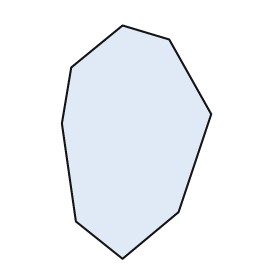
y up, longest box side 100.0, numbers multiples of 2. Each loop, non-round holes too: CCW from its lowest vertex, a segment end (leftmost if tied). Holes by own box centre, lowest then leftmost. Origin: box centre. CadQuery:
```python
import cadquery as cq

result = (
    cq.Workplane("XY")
    .moveTo(-6.0, -50.0)
    .lineTo(18.0, -30.0)
    .lineTo(32.0, 12.0)
    .lineTo(14.0, 44.0)
    .lineTo(-6.0, 50.0)
    .lineTo(-28.0, 32.0)
    .lineTo(-32.0, 8.0)
    .lineTo(-26.0, -34.0)
    .close()
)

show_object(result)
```